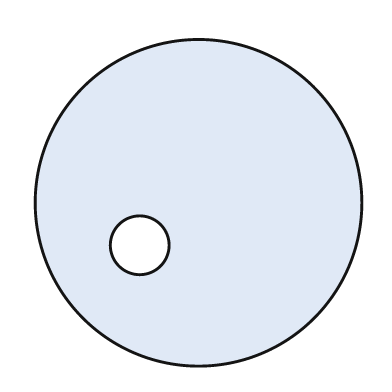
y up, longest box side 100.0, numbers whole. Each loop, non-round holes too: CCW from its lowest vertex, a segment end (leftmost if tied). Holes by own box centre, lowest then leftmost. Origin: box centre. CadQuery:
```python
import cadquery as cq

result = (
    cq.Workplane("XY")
    .moveTo(0.0, 0.0)
    .circle(50.0)
    .moveTo(-18.0, -13.0)
    .circle(9.0)
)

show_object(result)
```